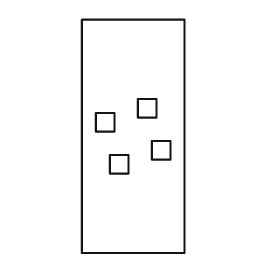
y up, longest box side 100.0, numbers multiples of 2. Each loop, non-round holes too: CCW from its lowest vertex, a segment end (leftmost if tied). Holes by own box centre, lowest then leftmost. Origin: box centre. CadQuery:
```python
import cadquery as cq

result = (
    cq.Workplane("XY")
    .moveTo(-22.0, -50.0)
    .lineTo(22.0, -50.0)
    .lineTo(22.0, 50.0)
    .lineTo(-22.0, 50.0)
    .close()
    .moveTo(-10.0, -16.0)
    .lineTo(-2.0, -16.0)
    .lineTo(-2.0, -8.0)
    .lineTo(-10.0, -8.0)
    .close()
    .moveTo(8.0, -10.0)
    .lineTo(16.0, -10.0)
    .lineTo(16.0, -2.0)
    .lineTo(8.0, -2.0)
    .close()
    .moveTo(-16.0, 2.0)
    .lineTo(-8.0, 2.0)
    .lineTo(-8.0, 10.0)
    .lineTo(-16.0, 10.0)
    .close()
    .moveTo(2.0, 8.0)
    .lineTo(10.0, 8.0)
    .lineTo(10.0, 16.0)
    .lineTo(2.0, 16.0)
    .close()
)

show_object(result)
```